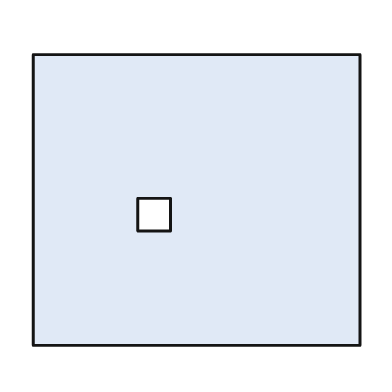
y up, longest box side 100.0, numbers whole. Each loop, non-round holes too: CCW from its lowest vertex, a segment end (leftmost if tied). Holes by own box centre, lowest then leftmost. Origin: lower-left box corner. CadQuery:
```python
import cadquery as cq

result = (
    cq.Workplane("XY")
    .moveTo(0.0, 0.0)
    .lineTo(100.0, 0.0)
    .lineTo(100.0, 89.0)
    .lineTo(0.0, 89.0)
    .close()
    .moveTo(32.0, 35.0)
    .lineTo(42.0, 35.0)
    .lineTo(42.0, 45.0)
    .lineTo(32.0, 45.0)
    .close()
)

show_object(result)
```